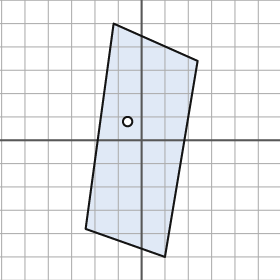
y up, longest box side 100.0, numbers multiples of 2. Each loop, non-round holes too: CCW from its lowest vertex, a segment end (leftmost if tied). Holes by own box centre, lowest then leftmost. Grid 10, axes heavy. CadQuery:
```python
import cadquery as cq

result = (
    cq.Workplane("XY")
    .moveTo(10.0, -50.0)
    .lineTo(24.0, 34.0)
    .lineTo(-12.0, 50.0)
    .lineTo(-24.0, -38.0)
    .close()
    .moveTo(-6.0, 8.0)
    .circle(2.0)
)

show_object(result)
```